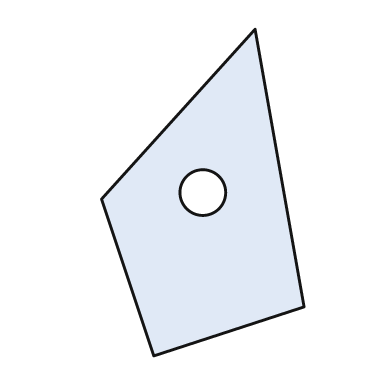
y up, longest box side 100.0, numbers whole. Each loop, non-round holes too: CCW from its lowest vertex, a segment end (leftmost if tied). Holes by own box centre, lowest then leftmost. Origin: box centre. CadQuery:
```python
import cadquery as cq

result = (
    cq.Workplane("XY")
    .moveTo(-15.0, -50.0)
    .lineTo(31.0, -35.0)
    .lineTo(16.0, 50.0)
    .lineTo(-31.0, -2.0)
    .close()
    .moveTo(0.0, 0.0)
    .circle(7.0)
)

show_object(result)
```